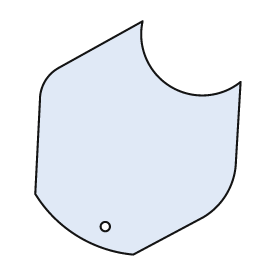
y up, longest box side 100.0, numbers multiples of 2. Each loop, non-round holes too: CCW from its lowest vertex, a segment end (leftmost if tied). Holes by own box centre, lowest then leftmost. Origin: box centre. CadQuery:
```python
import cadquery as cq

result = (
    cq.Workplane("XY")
    .moveTo(-2.0, -50.0)
    .lineTo(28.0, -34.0)
    .threePointArc((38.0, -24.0), (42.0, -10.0))
    .lineTo(44.0, 24.0)
    .threePointArc((14.0, 22.0), (2.0, 50.0))
    .lineTo(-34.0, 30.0)
    .threePointArc((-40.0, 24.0), (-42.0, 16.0))
    .lineTo(-44.0, -24.0)
    .threePointArc((-26.0, -42.0), (-2.0, -50.0))
    .close()
    .moveTo(-14.0, -38.0)
    .circle(2.0)
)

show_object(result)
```